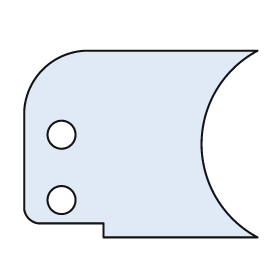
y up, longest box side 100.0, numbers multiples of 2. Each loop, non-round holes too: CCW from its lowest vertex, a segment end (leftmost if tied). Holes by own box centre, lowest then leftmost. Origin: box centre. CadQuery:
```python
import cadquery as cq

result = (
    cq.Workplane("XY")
    .moveTo(-16.0, -40.0)
    .lineTo(50.0, -40.0)
    .threePointArc((26.0, 0.0), (50.0, 40.0))
    .lineTo(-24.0, 40.0)
    .threePointArc((-42.0, 32.0), (-50.0, 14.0))
    .lineTo(-50.0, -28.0)
    .threePointArc((-48.0, -32.0), (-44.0, -34.0))
    .lineTo(-16.0, -34.0)
    .close()
    .moveTo(-34.0, -24.0)
    .circle(6.0)
    .moveTo(-34.0, 4.0)
    .circle(6.0)
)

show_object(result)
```